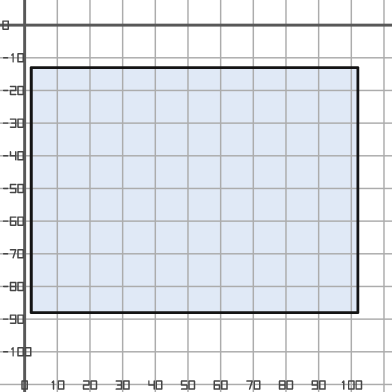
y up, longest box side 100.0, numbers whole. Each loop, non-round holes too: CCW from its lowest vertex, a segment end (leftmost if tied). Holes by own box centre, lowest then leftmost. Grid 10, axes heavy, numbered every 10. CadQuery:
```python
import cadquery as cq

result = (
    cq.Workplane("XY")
    .moveTo(2.0, -88.0)
    .lineTo(102.0, -88.0)
    .lineTo(102.0, -13.0)
    .lineTo(2.0, -13.0)
    .close()
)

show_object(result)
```